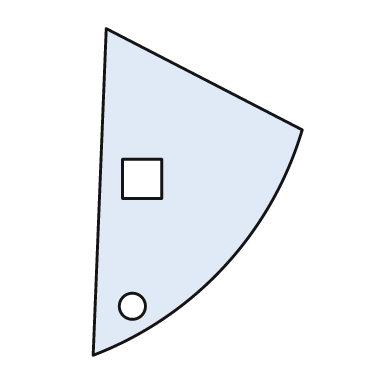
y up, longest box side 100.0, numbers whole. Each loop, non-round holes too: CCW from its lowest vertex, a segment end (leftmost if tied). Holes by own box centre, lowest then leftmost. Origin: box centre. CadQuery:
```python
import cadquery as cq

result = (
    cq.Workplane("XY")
    .moveTo(-32.0, -50.0)
    .threePointArc((8.0, -23.0), (32.0, 19.0))
    .lineTo(-28.0, 50.0)
    .close()
    .moveTo(-20.0, -35.0)
    .circle(4.0)
    .moveTo(-23.0, -2.0)
    .lineTo(-11.0, -2.0)
    .lineTo(-11.0, 10.0)
    .lineTo(-23.0, 10.0)
    .close()
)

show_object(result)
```